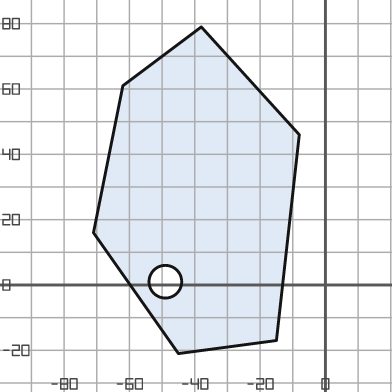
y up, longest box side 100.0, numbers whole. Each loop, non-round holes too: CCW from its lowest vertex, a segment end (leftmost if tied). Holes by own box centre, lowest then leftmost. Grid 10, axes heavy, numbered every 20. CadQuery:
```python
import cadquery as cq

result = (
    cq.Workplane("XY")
    .moveTo(-45.0, -21.0)
    .lineTo(-15.0, -17.0)
    .lineTo(-8.0, 46.0)
    .lineTo(-38.0, 79.0)
    .lineTo(-62.0, 61.0)
    .lineTo(-71.0, 16.0)
    .close()
    .moveTo(-49.0, 1.0)
    .circle(5.0)
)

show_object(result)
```